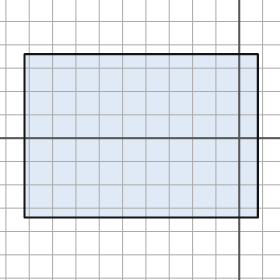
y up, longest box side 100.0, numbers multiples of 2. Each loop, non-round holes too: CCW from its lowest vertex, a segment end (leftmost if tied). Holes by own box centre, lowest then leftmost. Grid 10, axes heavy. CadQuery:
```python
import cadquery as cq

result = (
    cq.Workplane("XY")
    .moveTo(-92.0, -34.0)
    .lineTo(8.0, -34.0)
    .lineTo(8.0, 36.0)
    .lineTo(-92.0, 36.0)
    .close()
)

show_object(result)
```